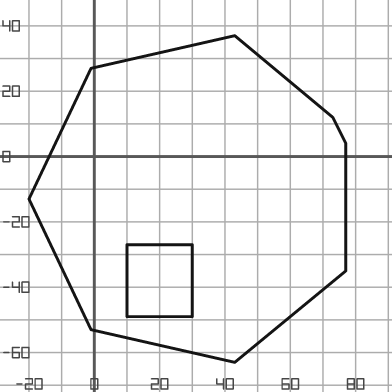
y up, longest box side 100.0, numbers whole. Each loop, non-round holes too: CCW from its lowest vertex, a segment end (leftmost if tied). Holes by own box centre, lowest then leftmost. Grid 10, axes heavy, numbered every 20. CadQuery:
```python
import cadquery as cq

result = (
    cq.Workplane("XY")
    .moveTo(43.0, -63.0)
    .lineTo(77.0, -35.0)
    .lineTo(77.0, 4.0)
    .lineTo(73.0, 12.0)
    .lineTo(43.0, 37.0)
    .lineTo(-1.0, 27.0)
    .lineTo(-20.0, -13.0)
    .lineTo(-1.0, -53.0)
    .close()
    .moveTo(10.0, -49.0)
    .lineTo(30.0, -49.0)
    .lineTo(30.0, -27.0)
    .lineTo(10.0, -27.0)
    .close()
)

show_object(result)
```